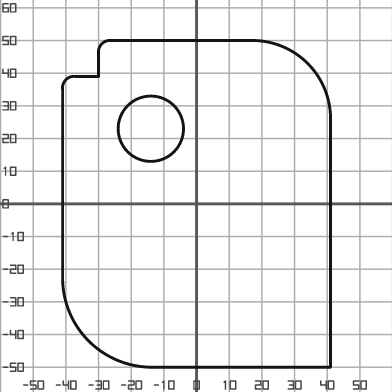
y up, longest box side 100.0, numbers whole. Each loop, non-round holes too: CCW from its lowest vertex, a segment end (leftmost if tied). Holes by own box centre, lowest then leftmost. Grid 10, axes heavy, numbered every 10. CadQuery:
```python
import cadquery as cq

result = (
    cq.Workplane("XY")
    .moveTo(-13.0, -50.0)
    .lineTo(41.0, -50.0)
    .lineTo(41.0, 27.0)
    .threePointArc((34.0, 43.0), (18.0, 50.0))
    .lineTo(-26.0, 50.0)
    .threePointArc((-29.0, 49.0), (-30.0, 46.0))
    .lineTo(-30.0, 39.0)
    .lineTo(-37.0, 39.0)
    .threePointArc((-40.0, 38.0), (-41.0, 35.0))
    .lineTo(-41.0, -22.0)
    .threePointArc((-33.0, -42.0), (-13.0, -50.0))
    .close()
    .moveTo(-14.0, 23.0)
    .circle(10.0)
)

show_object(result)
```